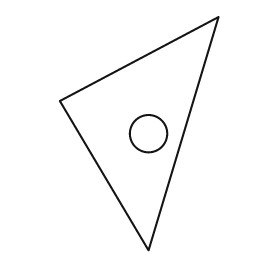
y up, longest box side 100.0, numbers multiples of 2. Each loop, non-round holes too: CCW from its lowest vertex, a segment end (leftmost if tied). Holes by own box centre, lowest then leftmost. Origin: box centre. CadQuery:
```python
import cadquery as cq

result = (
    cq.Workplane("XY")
    .moveTo(4.0, -50.0)
    .lineTo(34.0, 50.0)
    .lineTo(-34.0, 14.0)
    .close()
    .moveTo(4.0, 0.0)
    .circle(8.0)
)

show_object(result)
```